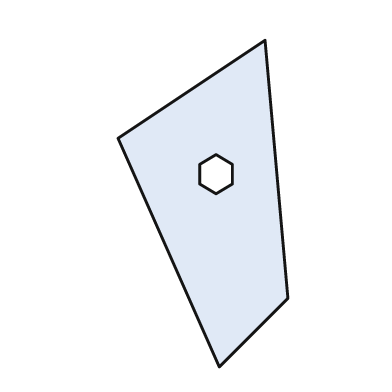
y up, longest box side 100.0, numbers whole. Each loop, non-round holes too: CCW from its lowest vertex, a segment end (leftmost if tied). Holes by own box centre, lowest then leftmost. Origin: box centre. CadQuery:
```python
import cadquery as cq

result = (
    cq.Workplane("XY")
    .moveTo(5.0, -50.0)
    .lineTo(26.0, -29.0)
    .lineTo(19.0, 50.0)
    .lineTo(-26.0, 20.0)
    .close()
    .moveTo(4.0, 3.0)
    .lineTo(9.0, 6.0)
    .lineTo(9.0, 12.0)
    .lineTo(4.0, 15.0)
    .lineTo(-1.0, 12.0)
    .lineTo(-1.0, 6.0)
    .close()
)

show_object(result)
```